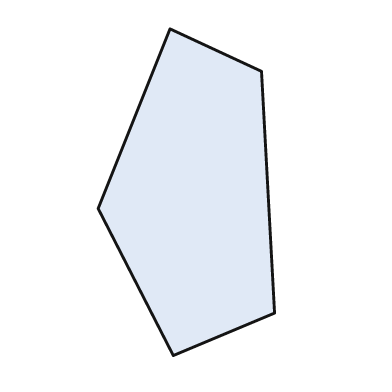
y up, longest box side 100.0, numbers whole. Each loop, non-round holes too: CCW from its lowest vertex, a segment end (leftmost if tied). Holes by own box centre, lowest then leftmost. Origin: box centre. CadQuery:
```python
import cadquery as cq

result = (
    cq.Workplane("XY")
    .moveTo(-4.0, -50.0)
    .lineTo(27.0, -37.0)
    .lineTo(23.0, 37.0)
    .lineTo(-5.0, 50.0)
    .lineTo(-27.0, -5.0)
    .close()
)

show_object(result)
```